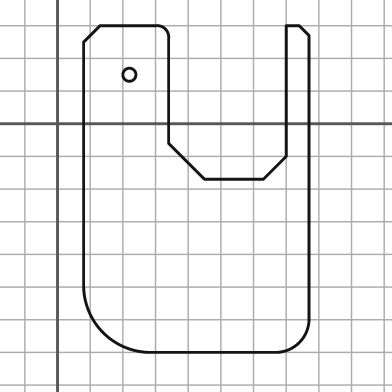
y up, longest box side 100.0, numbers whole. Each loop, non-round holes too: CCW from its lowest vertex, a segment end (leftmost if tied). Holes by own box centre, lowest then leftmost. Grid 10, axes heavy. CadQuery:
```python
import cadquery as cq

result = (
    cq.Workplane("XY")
    .moveTo(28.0, -70.0)
    .lineTo(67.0, -70.0)
    .threePointArc((74.0, -67.0), (77.0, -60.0))
    .lineTo(77.0, 27.0)
    .lineTo(74.0, 30.0)
    .lineTo(70.0, 30.0)
    .lineTo(70.0, -10.0)
    .lineTo(63.0, -17.0)
    .lineTo(45.0, -17.0)
    .lineTo(34.0, -6.0)
    .lineTo(34.0, 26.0)
    .threePointArc((33.0, 29.0), (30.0, 30.0))
    .lineTo(13.0, 30.0)
    .lineTo(8.0, 25.0)
    .lineTo(8.0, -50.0)
    .threePointArc((14.0, -64.0), (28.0, -70.0))
    .close()
    .moveTo(22.0, 15.0)
    .circle(2.0)
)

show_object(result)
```